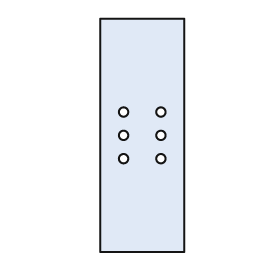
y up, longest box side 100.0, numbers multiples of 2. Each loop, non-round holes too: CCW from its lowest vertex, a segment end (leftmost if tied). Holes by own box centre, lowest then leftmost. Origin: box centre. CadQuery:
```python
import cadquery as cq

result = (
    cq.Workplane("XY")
    .moveTo(-18.0, -50.0)
    .lineTo(18.0, -50.0)
    .lineTo(18.0, 50.0)
    .lineTo(-18.0, 50.0)
    .close()
    .moveTo(-8.0, -10.0)
    .circle(2.0)
    .moveTo(8.0, -10.0)
    .circle(2.0)
    .moveTo(-8.0, 0.0)
    .circle(2.0)
    .moveTo(8.0, 0.0)
    .circle(2.0)
    .moveTo(-8.0, 10.0)
    .circle(2.0)
    .moveTo(8.0, 10.0)
    .circle(2.0)
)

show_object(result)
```